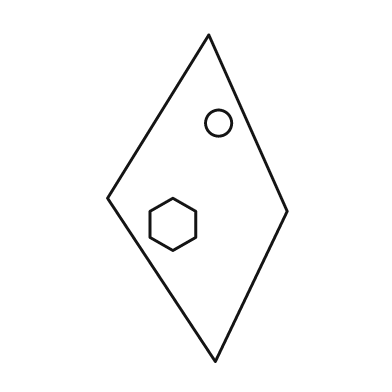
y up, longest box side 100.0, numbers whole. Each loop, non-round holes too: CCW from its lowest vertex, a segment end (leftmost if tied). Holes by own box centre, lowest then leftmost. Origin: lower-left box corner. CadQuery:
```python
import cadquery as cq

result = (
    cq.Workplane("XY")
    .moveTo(33.0, 0.0)
    .lineTo(55.0, 46.0)
    .lineTo(31.0, 100.0)
    .lineTo(0.0, 50.0)
    .close()
    .moveTo(20.0, 34.0)
    .lineTo(27.0, 38.0)
    .lineTo(27.0, 46.0)
    .lineTo(20.0, 50.0)
    .lineTo(13.0, 46.0)
    .lineTo(13.0, 38.0)
    .close()
    .moveTo(34.0, 73.0)
    .circle(4.0)
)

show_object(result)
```